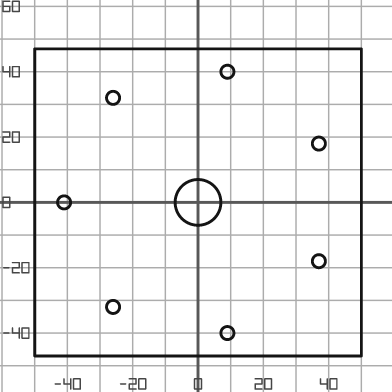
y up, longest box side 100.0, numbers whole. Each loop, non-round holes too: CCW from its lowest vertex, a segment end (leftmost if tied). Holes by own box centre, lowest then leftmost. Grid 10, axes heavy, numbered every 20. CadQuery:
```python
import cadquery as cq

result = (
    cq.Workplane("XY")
    .moveTo(-50.0, -47.0)
    .lineTo(50.0, -47.0)
    .lineTo(50.0, 47.0)
    .lineTo(-50.0, 47.0)
    .close()
    .moveTo(9.0, -40.0)
    .circle(2.0)
    .moveTo(-26.0, -32.0)
    .circle(2.0)
    .moveTo(37.0, -18.0)
    .circle(2.0)
    .moveTo(-41.0, 0.0)
    .circle(2.0)
    .moveTo(0.0, 0.0)
    .circle(7.0)
    .moveTo(37.0, 18.0)
    .circle(2.0)
    .moveTo(-26.0, 32.0)
    .circle(2.0)
    .moveTo(9.0, 40.0)
    .circle(2.0)
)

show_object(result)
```